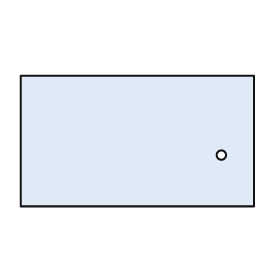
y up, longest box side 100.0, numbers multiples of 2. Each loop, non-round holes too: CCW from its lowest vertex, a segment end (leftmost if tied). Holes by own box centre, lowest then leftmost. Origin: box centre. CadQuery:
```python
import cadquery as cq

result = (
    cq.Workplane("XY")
    .moveTo(-50.0, -28.0)
    .lineTo(50.0, -28.0)
    .lineTo(50.0, 28.0)
    .lineTo(-50.0, 28.0)
    .close()
    .moveTo(36.0, -6.0)
    .circle(2.0)
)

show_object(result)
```